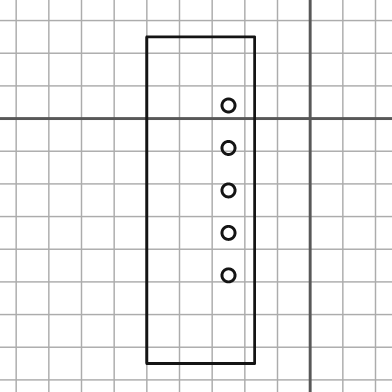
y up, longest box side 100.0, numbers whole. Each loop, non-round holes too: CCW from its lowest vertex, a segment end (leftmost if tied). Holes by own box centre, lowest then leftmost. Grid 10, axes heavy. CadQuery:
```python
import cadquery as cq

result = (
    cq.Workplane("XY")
    .moveTo(-50.0, -75.0)
    .lineTo(-17.0, -75.0)
    .lineTo(-17.0, 25.0)
    .lineTo(-50.0, 25.0)
    .close()
    .moveTo(-25.0, -48.0)
    .circle(2.0)
    .moveTo(-25.0, -35.0)
    .circle(2.0)
    .moveTo(-25.0, -22.0)
    .circle(2.0)
    .moveTo(-25.0, -9.0)
    .circle(2.0)
    .moveTo(-25.0, 4.0)
    .circle(2.0)
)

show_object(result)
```